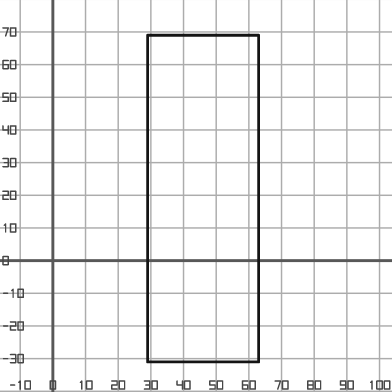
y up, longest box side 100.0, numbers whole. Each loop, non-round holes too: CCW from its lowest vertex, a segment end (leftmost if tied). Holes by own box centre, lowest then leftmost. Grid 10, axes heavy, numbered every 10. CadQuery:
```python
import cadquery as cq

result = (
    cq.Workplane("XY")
    .moveTo(29.0, -31.0)
    .lineTo(63.0, -31.0)
    .lineTo(63.0, 69.0)
    .lineTo(29.0, 69.0)
    .close()
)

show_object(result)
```